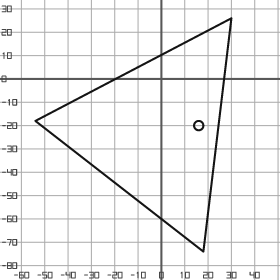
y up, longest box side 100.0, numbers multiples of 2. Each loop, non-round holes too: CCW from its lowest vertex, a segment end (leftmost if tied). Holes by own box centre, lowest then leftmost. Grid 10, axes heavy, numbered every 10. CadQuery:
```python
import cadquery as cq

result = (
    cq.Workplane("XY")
    .moveTo(18.0, -74.0)
    .lineTo(30.0, 26.0)
    .lineTo(-54.0, -18.0)
    .close()
    .moveTo(16.0, -20.0)
    .circle(2.0)
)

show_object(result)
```